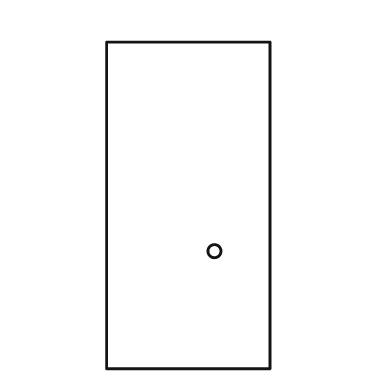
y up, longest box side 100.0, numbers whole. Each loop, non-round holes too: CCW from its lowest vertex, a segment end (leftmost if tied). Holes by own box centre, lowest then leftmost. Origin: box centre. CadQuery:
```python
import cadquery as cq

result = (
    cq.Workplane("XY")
    .moveTo(-25.0, -50.0)
    .lineTo(25.0, -50.0)
    .lineTo(25.0, 50.0)
    .lineTo(-25.0, 50.0)
    .close()
    .moveTo(8.0, -14.0)
    .circle(2.0)
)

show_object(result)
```